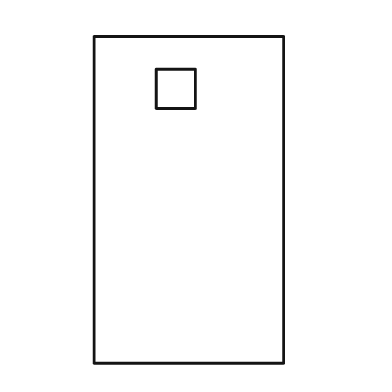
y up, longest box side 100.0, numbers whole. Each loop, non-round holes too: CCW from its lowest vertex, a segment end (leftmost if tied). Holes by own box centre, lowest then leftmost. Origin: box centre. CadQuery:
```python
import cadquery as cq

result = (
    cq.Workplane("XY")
    .moveTo(-29.0, -50.0)
    .lineTo(29.0, -50.0)
    .lineTo(29.0, 50.0)
    .lineTo(-29.0, 50.0)
    .close()
    .moveTo(-10.0, 28.0)
    .lineTo(2.0, 28.0)
    .lineTo(2.0, 40.0)
    .lineTo(-10.0, 40.0)
    .close()
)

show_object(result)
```